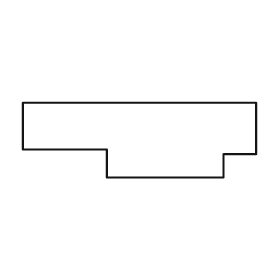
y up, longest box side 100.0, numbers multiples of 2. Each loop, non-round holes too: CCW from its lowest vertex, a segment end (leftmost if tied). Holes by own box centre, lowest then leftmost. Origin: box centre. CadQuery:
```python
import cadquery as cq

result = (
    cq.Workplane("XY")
    .moveTo(-14.0, -16.0)
    .lineTo(36.0, -16.0)
    .lineTo(36.0, -6.0)
    .lineTo(50.0, -6.0)
    .lineTo(50.0, 16.0)
    .lineTo(-50.0, 16.0)
    .lineTo(-50.0, -4.0)
    .lineTo(-14.0, -4.0)
    .close()
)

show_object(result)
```